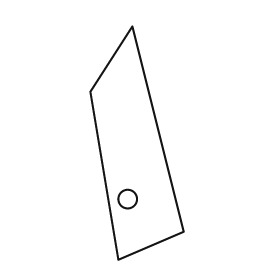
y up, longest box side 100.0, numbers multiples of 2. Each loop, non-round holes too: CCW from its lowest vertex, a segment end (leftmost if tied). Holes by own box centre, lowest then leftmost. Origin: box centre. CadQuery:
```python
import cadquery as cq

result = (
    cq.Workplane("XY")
    .moveTo(-8.0, -50.0)
    .lineTo(20.0, -38.0)
    .lineTo(-2.0, 50.0)
    .lineTo(-20.0, 22.0)
    .close()
    .moveTo(-4.0, -24.0)
    .circle(4.0)
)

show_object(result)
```